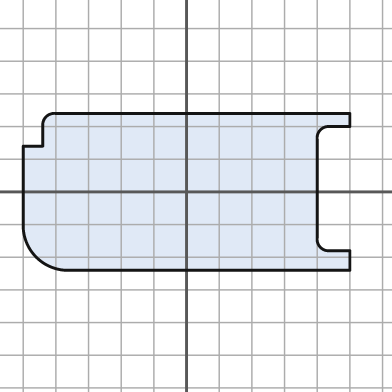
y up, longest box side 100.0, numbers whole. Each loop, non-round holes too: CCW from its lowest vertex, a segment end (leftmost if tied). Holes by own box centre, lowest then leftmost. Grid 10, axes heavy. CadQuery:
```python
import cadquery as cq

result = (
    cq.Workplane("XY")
    .moveTo(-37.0, -24.0)
    .lineTo(50.0, -24.0)
    .lineTo(50.0, -18.0)
    .lineTo(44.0, -18.0)
    .threePointArc((41.0, -17.0), (40.0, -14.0))
    .lineTo(40.0, 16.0)
    .threePointArc((41.0, 19.0), (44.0, 20.0))
    .lineTo(50.0, 20.0)
    .lineTo(50.0, 24.0)
    .lineTo(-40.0, 24.0)
    .threePointArc((-43.0, 23.0), (-44.0, 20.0))
    .lineTo(-44.0, 14.0)
    .lineTo(-50.0, 14.0)
    .lineTo(-50.0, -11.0)
    .threePointArc((-46.0, -20.0), (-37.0, -24.0))
    .close()
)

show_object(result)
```